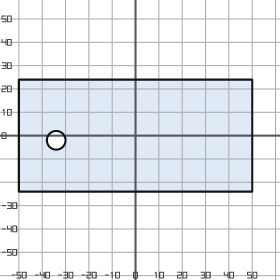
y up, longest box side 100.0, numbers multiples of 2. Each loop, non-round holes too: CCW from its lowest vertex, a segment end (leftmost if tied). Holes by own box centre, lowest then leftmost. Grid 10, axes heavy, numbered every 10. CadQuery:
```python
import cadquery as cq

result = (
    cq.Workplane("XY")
    .moveTo(-50.0, -24.0)
    .lineTo(50.0, -24.0)
    .lineTo(50.0, 24.0)
    .lineTo(-50.0, 24.0)
    .close()
    .moveTo(-34.0, -2.0)
    .circle(4.0)
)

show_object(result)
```